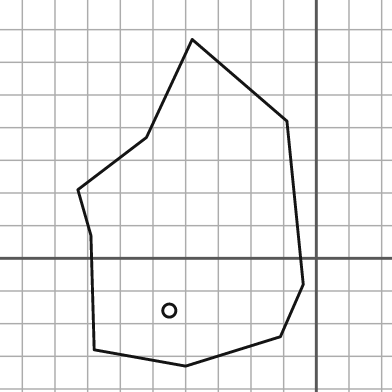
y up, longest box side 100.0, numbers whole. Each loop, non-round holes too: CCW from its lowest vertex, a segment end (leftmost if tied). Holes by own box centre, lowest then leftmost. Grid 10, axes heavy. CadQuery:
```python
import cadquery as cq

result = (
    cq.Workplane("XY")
    .moveTo(-40.0, -33.0)
    .lineTo(-11.0, -24.0)
    .lineTo(-4.0, -8.0)
    .lineTo(-9.0, 42.0)
    .lineTo(-38.0, 67.0)
    .lineTo(-52.0, 37.0)
    .lineTo(-73.0, 21.0)
    .lineTo(-69.0, 7.0)
    .lineTo(-68.0, -28.0)
    .close()
    .moveTo(-45.0, -16.0)
    .circle(2.0)
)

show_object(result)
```